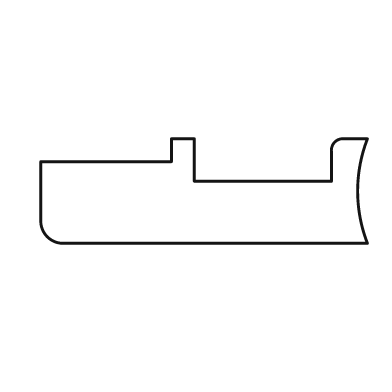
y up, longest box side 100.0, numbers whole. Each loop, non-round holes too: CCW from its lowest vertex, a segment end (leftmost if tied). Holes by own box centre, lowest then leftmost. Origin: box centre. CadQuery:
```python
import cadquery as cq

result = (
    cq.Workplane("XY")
    .moveTo(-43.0, -16.0)
    .lineTo(50.0, -16.0)
    .threePointArc((47.0, 0.0), (50.0, 16.0))
    .lineTo(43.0, 16.0)
    .threePointArc((40.0, 15.0), (39.0, 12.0))
    .lineTo(39.0, 3.0)
    .lineTo(-3.0, 3.0)
    .lineTo(-3.0, 16.0)
    .lineTo(-10.0, 16.0)
    .lineTo(-10.0, 9.0)
    .lineTo(-50.0, 9.0)
    .lineTo(-50.0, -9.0)
    .threePointArc((-48.0, -14.0), (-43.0, -16.0))
    .close()
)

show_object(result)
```